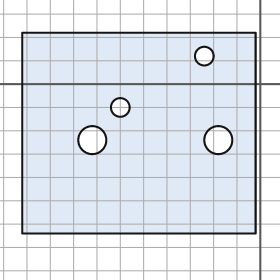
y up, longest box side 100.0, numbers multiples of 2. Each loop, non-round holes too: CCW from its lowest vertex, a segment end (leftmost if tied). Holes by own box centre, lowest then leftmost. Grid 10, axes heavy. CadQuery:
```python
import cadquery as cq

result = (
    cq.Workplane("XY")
    .moveTo(-102.0, -64.0)
    .lineTo(-2.0, -64.0)
    .lineTo(-2.0, 22.0)
    .lineTo(-102.0, 22.0)
    .close()
    .moveTo(-72.0, -24.0)
    .circle(6.0)
    .moveTo(-18.0, -24.0)
    .circle(6.0)
    .moveTo(-60.0, -10.0)
    .circle(4.0)
    .moveTo(-24.0, 12.0)
    .circle(4.0)
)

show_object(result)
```